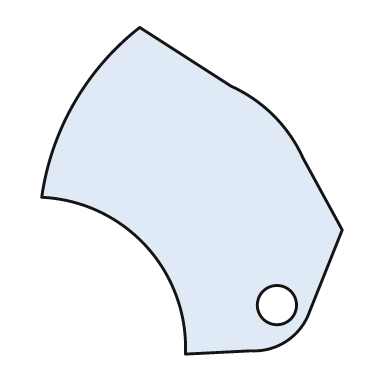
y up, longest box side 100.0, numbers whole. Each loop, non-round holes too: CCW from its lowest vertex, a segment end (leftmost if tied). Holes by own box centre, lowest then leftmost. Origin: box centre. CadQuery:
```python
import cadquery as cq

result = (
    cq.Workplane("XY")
    .moveTo(-2.0, -50.0)
    .lineTo(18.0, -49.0)
    .threePointArc((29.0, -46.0), (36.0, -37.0))
    .lineTo(46.0, -12.0)
    .lineTo(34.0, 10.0)
    .threePointArc((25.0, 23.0), (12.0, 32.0))
    .lineTo(-16.0, 50.0)
    .threePointArc((-36.0, 27.0), (-46.0, -2.0))
    .threePointArc((-14.0, -17.0), (-2.0, -50.0))
    .close()
    .moveTo(26.0, -35.0)
    .circle(6.0)
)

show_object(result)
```